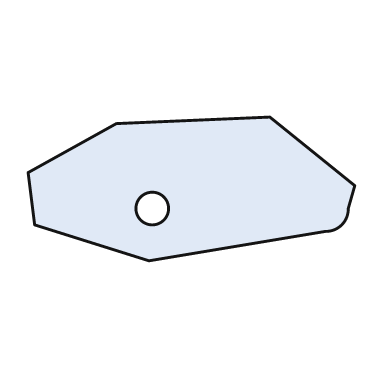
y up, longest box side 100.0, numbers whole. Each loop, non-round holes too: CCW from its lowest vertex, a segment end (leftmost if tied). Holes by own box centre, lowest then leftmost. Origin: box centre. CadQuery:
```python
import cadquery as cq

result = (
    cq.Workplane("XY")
    .moveTo(-13.0, -22.0)
    .lineTo(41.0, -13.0)
    .threePointArc((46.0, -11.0), (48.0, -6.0))
    .lineTo(50.0, 1.0)
    .lineTo(24.0, 22.0)
    .lineTo(-23.0, 20.0)
    .lineTo(-50.0, 5.0)
    .lineTo(-48.0, -11.0)
    .close()
    .moveTo(-12.0, -6.0)
    .circle(5.0)
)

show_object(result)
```